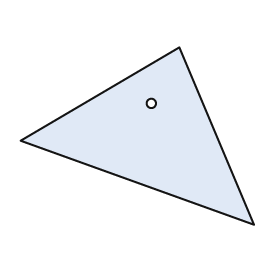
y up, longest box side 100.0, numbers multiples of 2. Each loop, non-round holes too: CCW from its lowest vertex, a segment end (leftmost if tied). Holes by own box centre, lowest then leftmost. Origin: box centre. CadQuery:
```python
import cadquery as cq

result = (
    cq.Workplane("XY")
    .moveTo(50.0, -38.0)
    .lineTo(18.0, 38.0)
    .lineTo(-50.0, -2.0)
    .close()
    .moveTo(6.0, 14.0)
    .circle(2.0)
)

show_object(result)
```